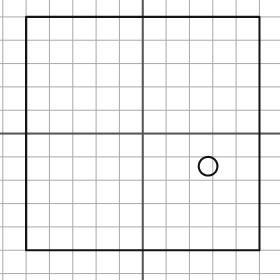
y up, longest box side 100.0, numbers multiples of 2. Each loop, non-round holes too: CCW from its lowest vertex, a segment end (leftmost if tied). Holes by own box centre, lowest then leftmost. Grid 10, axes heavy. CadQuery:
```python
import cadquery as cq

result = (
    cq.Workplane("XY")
    .moveTo(-50.0, -50.0)
    .lineTo(50.0, -50.0)
    .lineTo(50.0, 50.0)
    .lineTo(-50.0, 50.0)
    .close()
    .moveTo(28.0, -14.0)
    .circle(4.0)
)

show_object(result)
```